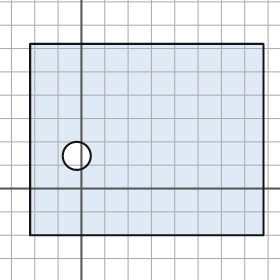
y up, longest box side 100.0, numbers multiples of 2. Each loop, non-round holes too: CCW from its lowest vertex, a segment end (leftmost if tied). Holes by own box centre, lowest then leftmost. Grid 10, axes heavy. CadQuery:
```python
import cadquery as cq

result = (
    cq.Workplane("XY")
    .moveTo(-22.0, -20.0)
    .lineTo(78.0, -20.0)
    .lineTo(78.0, 62.0)
    .lineTo(-22.0, 62.0)
    .close()
    .moveTo(-2.0, 14.0)
    .circle(6.0)
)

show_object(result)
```